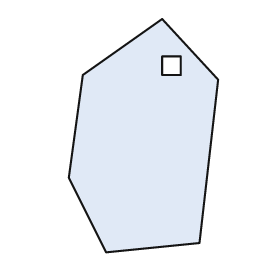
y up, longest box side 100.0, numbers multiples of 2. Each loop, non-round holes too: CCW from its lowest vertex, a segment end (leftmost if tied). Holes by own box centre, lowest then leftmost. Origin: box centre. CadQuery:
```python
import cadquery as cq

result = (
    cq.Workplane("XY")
    .moveTo(-16.0, -50.0)
    .lineTo(24.0, -46.0)
    .lineTo(32.0, 24.0)
    .lineTo(8.0, 50.0)
    .lineTo(-26.0, 26.0)
    .lineTo(-32.0, -18.0)
    .close()
    .moveTo(8.0, 26.0)
    .lineTo(16.0, 26.0)
    .lineTo(16.0, 34.0)
    .lineTo(8.0, 34.0)
    .close()
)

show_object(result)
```